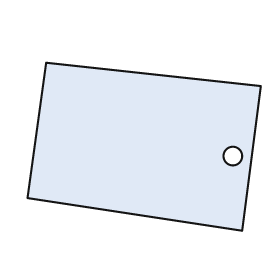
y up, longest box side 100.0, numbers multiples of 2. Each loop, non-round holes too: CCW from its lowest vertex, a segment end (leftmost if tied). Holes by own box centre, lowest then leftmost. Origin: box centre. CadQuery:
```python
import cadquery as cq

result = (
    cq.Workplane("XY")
    .moveTo(42.0, -36.0)
    .lineTo(50.0, 26.0)
    .lineTo(-42.0, 36.0)
    .lineTo(-50.0, -22.0)
    .close()
    .moveTo(38.0, -4.0)
    .circle(4.0)
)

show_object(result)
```